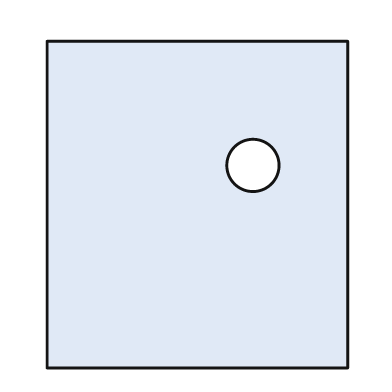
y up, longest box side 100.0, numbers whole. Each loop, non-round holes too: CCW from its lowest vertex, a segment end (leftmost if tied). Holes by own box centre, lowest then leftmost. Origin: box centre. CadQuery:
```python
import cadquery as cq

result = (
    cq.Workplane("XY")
    .moveTo(-46.0, -50.0)
    .lineTo(46.0, -50.0)
    .lineTo(46.0, 50.0)
    .lineTo(-46.0, 50.0)
    .close()
    .moveTo(17.0, 12.0)
    .circle(8.0)
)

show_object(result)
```